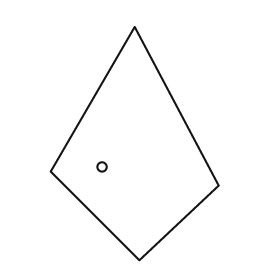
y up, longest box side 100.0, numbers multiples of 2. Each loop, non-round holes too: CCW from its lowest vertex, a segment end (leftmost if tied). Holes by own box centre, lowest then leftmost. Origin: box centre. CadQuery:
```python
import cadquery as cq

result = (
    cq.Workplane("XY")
    .moveTo(2.0, -50.0)
    .lineTo(36.0, -18.0)
    .lineTo(0.0, 50.0)
    .lineTo(-36.0, -12.0)
    .close()
    .moveTo(-14.0, -10.0)
    .circle(2.0)
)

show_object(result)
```